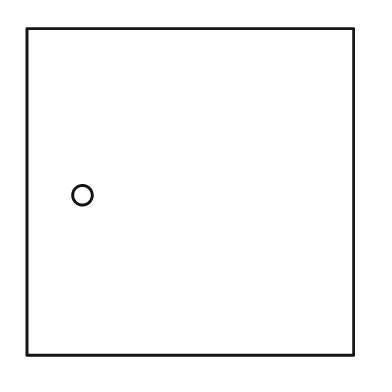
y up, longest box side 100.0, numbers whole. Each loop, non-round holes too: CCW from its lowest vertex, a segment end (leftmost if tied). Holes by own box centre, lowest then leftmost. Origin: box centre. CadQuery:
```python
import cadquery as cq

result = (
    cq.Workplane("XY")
    .moveTo(-50.0, -50.0)
    .lineTo(50.0, -50.0)
    .lineTo(50.0, 50.0)
    .lineTo(-50.0, 50.0)
    .close()
    .moveTo(-33.0, -1.0)
    .circle(3.0)
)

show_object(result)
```